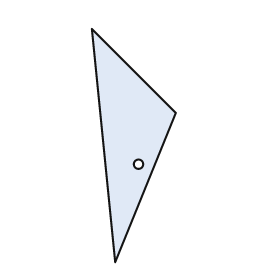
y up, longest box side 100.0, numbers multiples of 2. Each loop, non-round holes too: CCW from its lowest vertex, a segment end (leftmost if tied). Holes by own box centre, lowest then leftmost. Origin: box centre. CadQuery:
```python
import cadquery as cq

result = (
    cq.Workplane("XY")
    .moveTo(-8.0, -50.0)
    .lineTo(18.0, 14.0)
    .lineTo(-18.0, 50.0)
    .close()
    .moveTo(2.0, -8.0)
    .circle(2.0)
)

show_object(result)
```